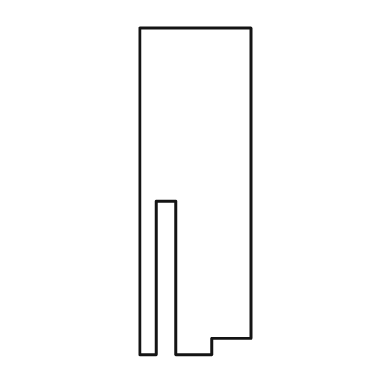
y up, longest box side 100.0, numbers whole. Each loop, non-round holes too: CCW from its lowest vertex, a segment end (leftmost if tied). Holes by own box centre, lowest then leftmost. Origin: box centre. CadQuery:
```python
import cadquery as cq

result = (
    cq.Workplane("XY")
    .moveTo(-17.0, -50.0)
    .lineTo(-12.0, -50.0)
    .lineTo(-12.0, -3.0)
    .lineTo(-6.0, -3.0)
    .lineTo(-6.0, -50.0)
    .lineTo(5.0, -50.0)
    .lineTo(5.0, -45.0)
    .lineTo(17.0, -45.0)
    .lineTo(17.0, 50.0)
    .lineTo(-17.0, 50.0)
    .close()
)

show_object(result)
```